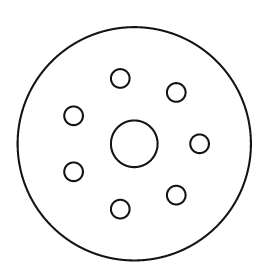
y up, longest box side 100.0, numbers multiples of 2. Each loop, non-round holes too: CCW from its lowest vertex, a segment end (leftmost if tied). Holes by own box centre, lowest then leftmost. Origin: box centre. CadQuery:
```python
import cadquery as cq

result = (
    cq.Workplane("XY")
    .moveTo(0.0, 0.0)
    .circle(50.0)
    .moveTo(-6.0, -28.0)
    .circle(4.0)
    .moveTo(18.0, -22.0)
    .circle(4.0)
    .moveTo(-26.0, -12.0)
    .circle(4.0)
    .moveTo(0.0, 0.0)
    .circle(10.0)
    .moveTo(28.0, 0.0)
    .circle(4.0)
    .moveTo(-26.0, 12.0)
    .circle(4.0)
    .moveTo(18.0, 22.0)
    .circle(4.0)
    .moveTo(-6.0, 28.0)
    .circle(4.0)
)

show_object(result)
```